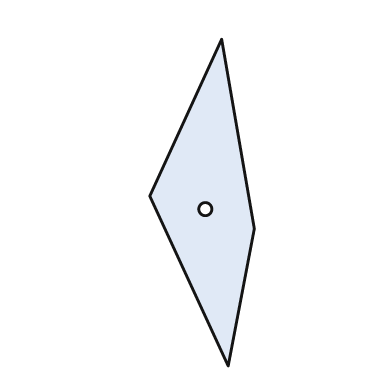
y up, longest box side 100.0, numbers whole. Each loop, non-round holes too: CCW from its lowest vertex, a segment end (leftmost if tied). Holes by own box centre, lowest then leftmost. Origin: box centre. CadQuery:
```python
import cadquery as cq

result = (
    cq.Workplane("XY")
    .moveTo(8.0, -50.0)
    .lineTo(16.0, -8.0)
    .lineTo(6.0, 50.0)
    .lineTo(-16.0, 2.0)
    .close()
    .moveTo(1.0, -2.0)
    .circle(2.0)
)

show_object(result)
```